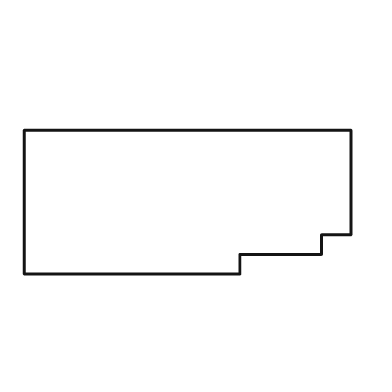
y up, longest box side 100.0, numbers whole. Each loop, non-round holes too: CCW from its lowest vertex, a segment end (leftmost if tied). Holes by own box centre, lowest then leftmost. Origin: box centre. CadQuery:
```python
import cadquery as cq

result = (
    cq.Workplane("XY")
    .moveTo(-50.0, -22.0)
    .lineTo(16.0, -22.0)
    .lineTo(16.0, -16.0)
    .lineTo(41.0, -16.0)
    .lineTo(41.0, -10.0)
    .lineTo(50.0, -10.0)
    .lineTo(50.0, 22.0)
    .lineTo(-50.0, 22.0)
    .close()
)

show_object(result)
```